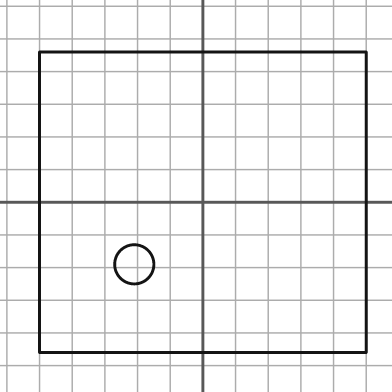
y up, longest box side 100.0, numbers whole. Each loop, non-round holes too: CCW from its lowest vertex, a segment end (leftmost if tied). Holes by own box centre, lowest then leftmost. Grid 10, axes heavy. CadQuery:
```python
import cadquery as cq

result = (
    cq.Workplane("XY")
    .moveTo(-50.0, -46.0)
    .lineTo(50.0, -46.0)
    .lineTo(50.0, 46.0)
    .lineTo(-50.0, 46.0)
    .close()
    .moveTo(-21.0, -19.0)
    .circle(6.0)
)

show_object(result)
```